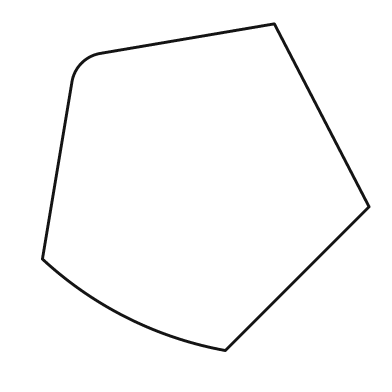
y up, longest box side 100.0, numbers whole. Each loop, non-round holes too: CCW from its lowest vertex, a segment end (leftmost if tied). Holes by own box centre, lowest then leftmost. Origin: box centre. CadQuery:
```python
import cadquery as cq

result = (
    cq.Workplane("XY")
    .moveTo(6.0, -50.0)
    .lineTo(50.0, -6.0)
    .lineTo(21.0, 50.0)
    .lineTo(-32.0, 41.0)
    .threePointArc((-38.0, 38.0), (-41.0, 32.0))
    .lineTo(-50.0, -22.0)
    .threePointArc((-24.0, -40.0), (6.0, -50.0))
    .close()
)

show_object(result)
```